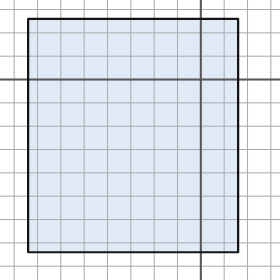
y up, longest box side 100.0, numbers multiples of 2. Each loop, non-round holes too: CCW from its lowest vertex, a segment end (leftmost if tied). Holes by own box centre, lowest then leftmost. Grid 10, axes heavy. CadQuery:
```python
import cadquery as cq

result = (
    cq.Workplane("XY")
    .moveTo(-74.0, -74.0)
    .lineTo(16.0, -74.0)
    .lineTo(16.0, 26.0)
    .lineTo(-74.0, 26.0)
    .close()
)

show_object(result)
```